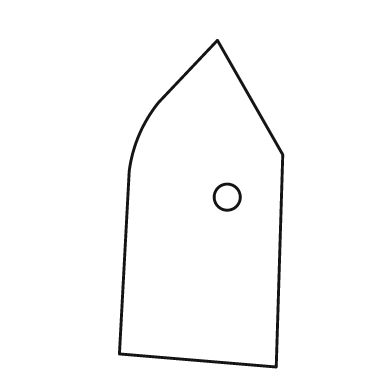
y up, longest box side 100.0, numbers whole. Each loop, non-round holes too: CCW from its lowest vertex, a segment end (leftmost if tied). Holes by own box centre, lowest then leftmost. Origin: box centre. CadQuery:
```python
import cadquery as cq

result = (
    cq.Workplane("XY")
    .moveTo(23.0, -50.0)
    .lineTo(25.0, 15.0)
    .lineTo(5.0, 50.0)
    .lineTo(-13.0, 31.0)
    .threePointArc((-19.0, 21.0), (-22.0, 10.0))
    .lineTo(-25.0, -46.0)
    .close()
    .moveTo(8.0, 2.0)
    .circle(4.0)
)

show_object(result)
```